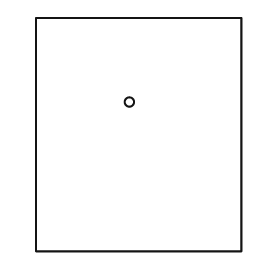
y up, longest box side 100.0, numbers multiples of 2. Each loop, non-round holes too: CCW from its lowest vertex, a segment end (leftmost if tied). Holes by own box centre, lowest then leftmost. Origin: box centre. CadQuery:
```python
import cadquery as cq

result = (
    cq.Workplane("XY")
    .moveTo(-44.0, -50.0)
    .lineTo(44.0, -50.0)
    .lineTo(44.0, 50.0)
    .lineTo(-44.0, 50.0)
    .close()
    .moveTo(-4.0, 14.0)
    .circle(2.0)
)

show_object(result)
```